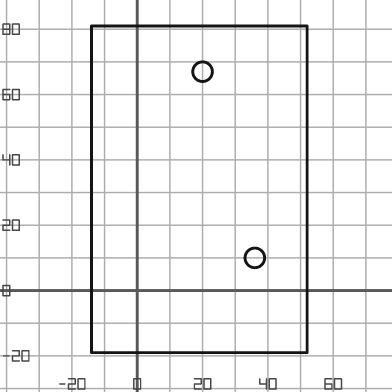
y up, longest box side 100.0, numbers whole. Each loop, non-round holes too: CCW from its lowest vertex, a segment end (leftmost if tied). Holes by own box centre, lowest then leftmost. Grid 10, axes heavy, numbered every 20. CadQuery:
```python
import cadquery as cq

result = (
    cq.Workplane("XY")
    .moveTo(-14.0, -19.0)
    .lineTo(52.0, -19.0)
    .lineTo(52.0, 81.0)
    .lineTo(-14.0, 81.0)
    .close()
    .moveTo(36.0, 10.0)
    .circle(3.0)
    .moveTo(20.0, 67.0)
    .circle(3.0)
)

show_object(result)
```